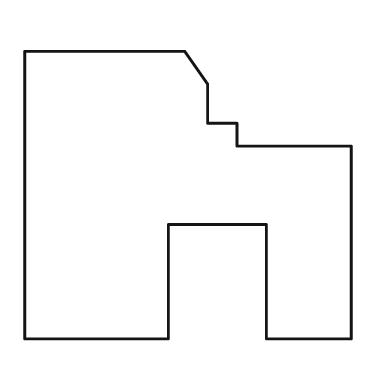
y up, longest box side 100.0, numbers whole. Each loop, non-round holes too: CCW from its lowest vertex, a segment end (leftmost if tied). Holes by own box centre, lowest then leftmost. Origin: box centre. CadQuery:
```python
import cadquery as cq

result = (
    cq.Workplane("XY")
    .moveTo(-50.0, -44.0)
    .lineTo(-6.0, -44.0)
    .lineTo(-6.0, -9.0)
    .lineTo(24.0, -9.0)
    .lineTo(24.0, -44.0)
    .lineTo(50.0, -44.0)
    .lineTo(50.0, 15.0)
    .lineTo(15.0, 15.0)
    .lineTo(15.0, 22.0)
    .lineTo(6.0, 22.0)
    .lineTo(6.0, 34.0)
    .lineTo(-1.0, 44.0)
    .lineTo(-50.0, 44.0)
    .close()
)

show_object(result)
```